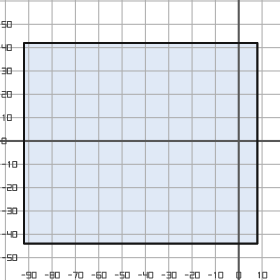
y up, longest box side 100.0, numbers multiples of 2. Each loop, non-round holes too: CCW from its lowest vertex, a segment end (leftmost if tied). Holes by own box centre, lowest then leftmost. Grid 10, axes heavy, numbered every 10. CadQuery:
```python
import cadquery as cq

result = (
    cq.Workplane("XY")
    .moveTo(-92.0, -44.0)
    .lineTo(8.0, -44.0)
    .lineTo(8.0, 42.0)
    .lineTo(-92.0, 42.0)
    .close()
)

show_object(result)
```